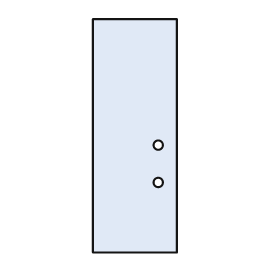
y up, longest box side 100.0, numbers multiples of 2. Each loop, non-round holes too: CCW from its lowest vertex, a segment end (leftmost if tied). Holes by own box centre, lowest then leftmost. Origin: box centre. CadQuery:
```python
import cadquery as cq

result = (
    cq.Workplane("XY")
    .moveTo(-18.0, -50.0)
    .lineTo(18.0, -50.0)
    .lineTo(18.0, 50.0)
    .lineTo(-18.0, 50.0)
    .close()
    .moveTo(10.0, -20.0)
    .circle(2.0)
    .moveTo(10.0, -4.0)
    .circle(2.0)
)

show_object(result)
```